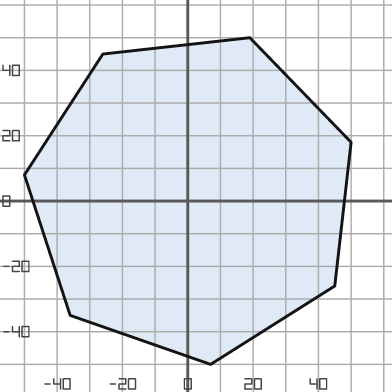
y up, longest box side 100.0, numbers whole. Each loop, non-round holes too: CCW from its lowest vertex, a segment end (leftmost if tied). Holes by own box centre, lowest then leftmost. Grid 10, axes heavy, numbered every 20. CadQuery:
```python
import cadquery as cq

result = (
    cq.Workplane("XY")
    .moveTo(7.0, -50.0)
    .lineTo(45.0, -26.0)
    .lineTo(50.0, 18.0)
    .lineTo(19.0, 50.0)
    .lineTo(-26.0, 45.0)
    .lineTo(-50.0, 8.0)
    .lineTo(-36.0, -35.0)
    .close()
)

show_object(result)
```